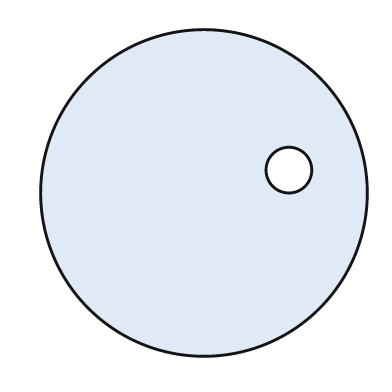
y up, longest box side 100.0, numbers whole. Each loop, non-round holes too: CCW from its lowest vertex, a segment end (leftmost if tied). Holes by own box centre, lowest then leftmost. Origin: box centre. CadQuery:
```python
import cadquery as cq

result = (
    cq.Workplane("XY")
    .moveTo(0.0, 0.0)
    .circle(50.0)
    .moveTo(26.0, 7.0)
    .circle(7.0)
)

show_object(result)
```